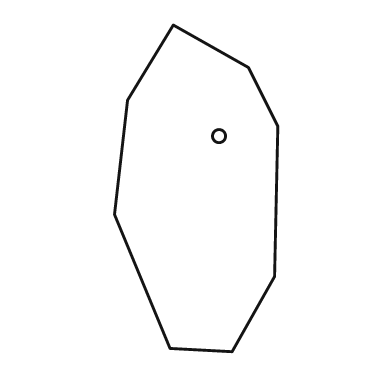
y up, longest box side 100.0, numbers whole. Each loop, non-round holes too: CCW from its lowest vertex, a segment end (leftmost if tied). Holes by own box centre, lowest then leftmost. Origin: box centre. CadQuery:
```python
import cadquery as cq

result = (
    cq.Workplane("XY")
    .moveTo(11.0, -50.0)
    .lineTo(24.0, -27.0)
    .lineTo(25.0, 19.0)
    .lineTo(16.0, 37.0)
    .lineTo(-7.0, 50.0)
    .lineTo(-21.0, 27.0)
    .lineTo(-25.0, -8.0)
    .lineTo(-8.0, -49.0)
    .close()
    .moveTo(7.0, 16.0)
    .circle(2.0)
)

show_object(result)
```